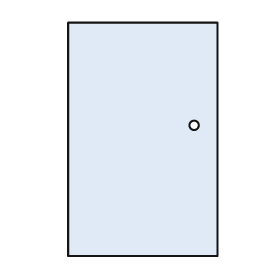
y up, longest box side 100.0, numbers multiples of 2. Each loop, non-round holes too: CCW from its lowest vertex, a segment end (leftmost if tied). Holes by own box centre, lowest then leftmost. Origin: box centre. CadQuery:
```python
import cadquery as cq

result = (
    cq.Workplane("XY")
    .moveTo(-32.0, -50.0)
    .lineTo(32.0, -50.0)
    .lineTo(32.0, 50.0)
    .lineTo(-32.0, 50.0)
    .close()
    .moveTo(22.0, 6.0)
    .circle(2.0)
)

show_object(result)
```